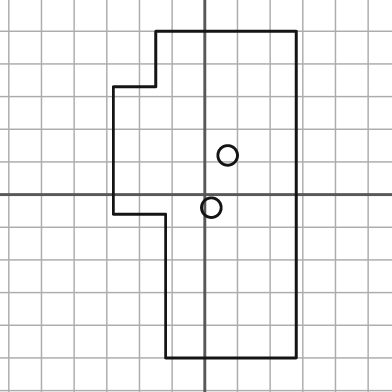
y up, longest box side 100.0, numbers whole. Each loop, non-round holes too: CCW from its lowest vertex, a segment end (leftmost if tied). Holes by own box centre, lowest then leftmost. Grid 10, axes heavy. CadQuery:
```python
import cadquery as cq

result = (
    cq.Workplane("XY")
    .moveTo(-12.0, -50.0)
    .lineTo(28.0, -50.0)
    .lineTo(28.0, 50.0)
    .lineTo(-15.0, 50.0)
    .lineTo(-15.0, 33.0)
    .lineTo(-28.0, 33.0)
    .lineTo(-28.0, -6.0)
    .lineTo(-12.0, -6.0)
    .close()
    .moveTo(2.0, -4.0)
    .circle(3.0)
    .moveTo(7.0, 12.0)
    .circle(3.0)
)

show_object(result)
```